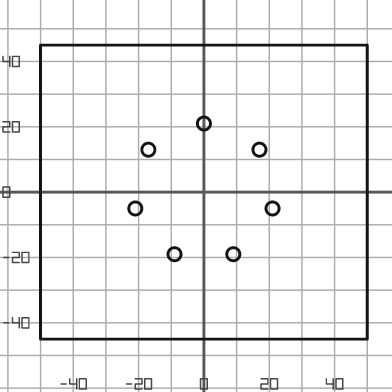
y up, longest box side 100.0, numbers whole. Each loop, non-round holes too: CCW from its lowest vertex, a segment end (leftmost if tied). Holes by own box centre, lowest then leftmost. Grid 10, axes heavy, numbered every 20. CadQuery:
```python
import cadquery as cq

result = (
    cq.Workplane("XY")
    .moveTo(-50.0, -45.0)
    .lineTo(50.0, -45.0)
    .lineTo(50.0, 45.0)
    .lineTo(-50.0, 45.0)
    .close()
    .moveTo(-9.0, -19.0)
    .circle(2.0)
    .moveTo(9.0, -19.0)
    .circle(2.0)
    .moveTo(-21.0, -5.0)
    .circle(2.0)
    .moveTo(21.0, -5.0)
    .circle(2.0)
    .moveTo(-17.0, 13.0)
    .circle(2.0)
    .moveTo(17.0, 13.0)
    .circle(2.0)
    .moveTo(0.0, 21.0)
    .circle(2.0)
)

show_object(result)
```